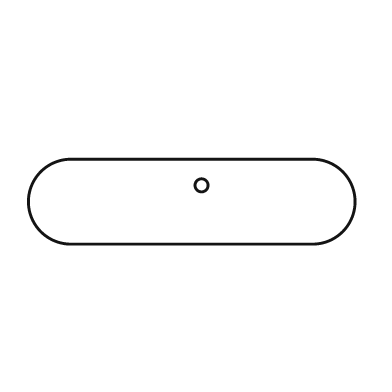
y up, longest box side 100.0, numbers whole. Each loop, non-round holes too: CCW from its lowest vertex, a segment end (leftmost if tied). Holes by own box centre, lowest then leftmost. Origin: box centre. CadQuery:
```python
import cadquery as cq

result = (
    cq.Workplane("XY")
    .moveTo(-37.0, -13.0)
    .lineTo(37.0, -13.0)
    .threePointArc((50.0, 0.0), (37.0, 13.0))
    .lineTo(-37.0, 13.0)
    .threePointArc((-50.0, 0.0), (-37.0, -13.0))
    .close()
    .moveTo(3.0, 5.0)
    .circle(2.0)
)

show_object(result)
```